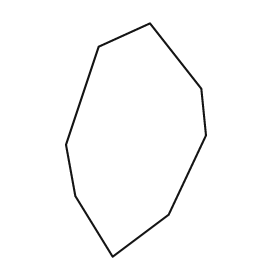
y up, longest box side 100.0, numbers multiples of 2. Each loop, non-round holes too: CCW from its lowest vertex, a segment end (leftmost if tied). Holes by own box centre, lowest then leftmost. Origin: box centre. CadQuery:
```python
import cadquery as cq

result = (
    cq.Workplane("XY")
    .moveTo(-10.0, -50.0)
    .lineTo(14.0, -32.0)
    .lineTo(30.0, 2.0)
    .lineTo(28.0, 22.0)
    .lineTo(6.0, 50.0)
    .lineTo(-16.0, 40.0)
    .lineTo(-30.0, -2.0)
    .lineTo(-26.0, -24.0)
    .close()
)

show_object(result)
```